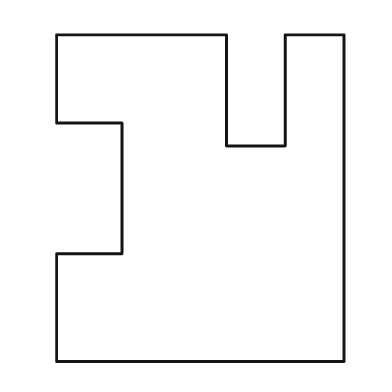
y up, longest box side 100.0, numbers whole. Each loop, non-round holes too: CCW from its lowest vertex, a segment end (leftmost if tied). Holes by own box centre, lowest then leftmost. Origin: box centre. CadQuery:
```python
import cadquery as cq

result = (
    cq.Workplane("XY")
    .moveTo(-44.0, -50.0)
    .lineTo(44.0, -50.0)
    .lineTo(44.0, 50.0)
    .lineTo(26.0, 50.0)
    .lineTo(26.0, 16.0)
    .lineTo(8.0, 16.0)
    .lineTo(8.0, 50.0)
    .lineTo(-44.0, 50.0)
    .lineTo(-44.0, 23.0)
    .lineTo(-24.0, 23.0)
    .lineTo(-24.0, -17.0)
    .lineTo(-44.0, -17.0)
    .close()
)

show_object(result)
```